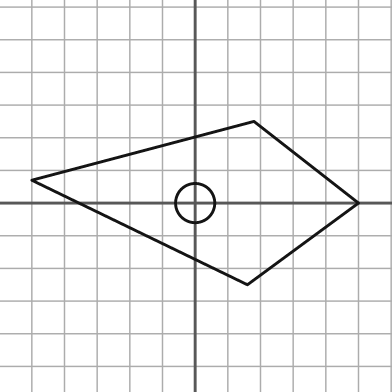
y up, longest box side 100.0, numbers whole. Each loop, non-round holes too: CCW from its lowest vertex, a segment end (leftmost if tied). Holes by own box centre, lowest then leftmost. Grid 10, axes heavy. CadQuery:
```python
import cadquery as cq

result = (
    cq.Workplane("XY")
    .moveTo(16.0, -25.0)
    .lineTo(50.0, 0.0)
    .lineTo(18.0, 25.0)
    .lineTo(-50.0, 7.0)
    .close()
    .moveTo(0.0, 0.0)
    .circle(6.0)
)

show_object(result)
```